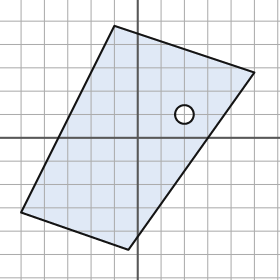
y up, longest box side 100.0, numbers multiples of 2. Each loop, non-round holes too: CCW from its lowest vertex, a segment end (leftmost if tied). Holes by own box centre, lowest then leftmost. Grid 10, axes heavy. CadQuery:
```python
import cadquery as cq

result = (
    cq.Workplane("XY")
    .moveTo(-4.0, -48.0)
    .lineTo(50.0, 28.0)
    .lineTo(-10.0, 48.0)
    .lineTo(-50.0, -32.0)
    .close()
    .moveTo(20.0, 10.0)
    .circle(4.0)
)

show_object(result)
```